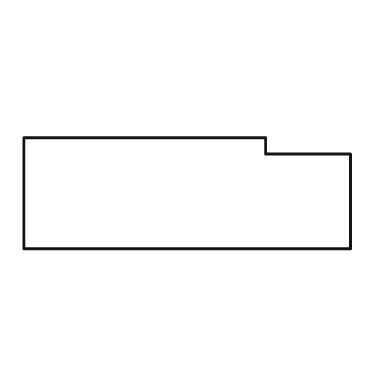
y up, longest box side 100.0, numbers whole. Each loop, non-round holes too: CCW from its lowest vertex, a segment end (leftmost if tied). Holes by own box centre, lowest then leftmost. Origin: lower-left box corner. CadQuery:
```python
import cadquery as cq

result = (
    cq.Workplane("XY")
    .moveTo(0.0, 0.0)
    .lineTo(100.0, 0.0)
    .lineTo(100.0, 29.0)
    .lineTo(74.0, 29.0)
    .lineTo(74.0, 34.0)
    .lineTo(0.0, 34.0)
    .close()
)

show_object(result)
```